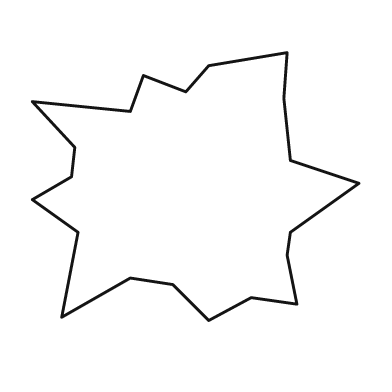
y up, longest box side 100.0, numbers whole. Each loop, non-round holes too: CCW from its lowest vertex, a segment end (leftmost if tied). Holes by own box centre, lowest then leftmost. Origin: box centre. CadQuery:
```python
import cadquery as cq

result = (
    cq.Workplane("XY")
    .moveTo(4.0, -41.0)
    .lineTo(17.0, -34.0)
    .lineTo(31.0, -36.0)
    .lineTo(28.0, -21.0)
    .lineTo(29.0, -14.0)
    .lineTo(50.0, 1.0)
    .lineTo(29.0, 8.0)
    .lineTo(27.0, 27.0)
    .lineTo(28.0, 41.0)
    .lineTo(4.0, 37.0)
    .lineTo(-3.0, 29.0)
    .lineTo(-16.0, 34.0)
    .lineTo(-20.0, 23.0)
    .lineTo(-50.0, 26.0)
    .lineTo(-37.0, 12.0)
    .lineTo(-38.0, 3.0)
    .lineTo(-50.0, -4.0)
    .lineTo(-36.0, -14.0)
    .lineTo(-41.0, -40.0)
    .lineTo(-20.0, -28.0)
    .lineTo(-7.0, -30.0)
    .close()
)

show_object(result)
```